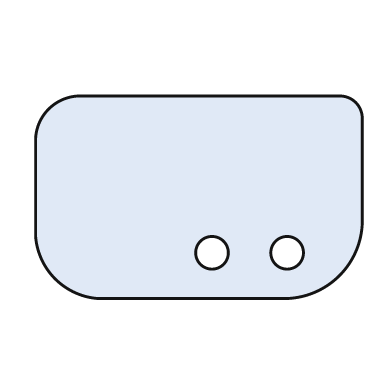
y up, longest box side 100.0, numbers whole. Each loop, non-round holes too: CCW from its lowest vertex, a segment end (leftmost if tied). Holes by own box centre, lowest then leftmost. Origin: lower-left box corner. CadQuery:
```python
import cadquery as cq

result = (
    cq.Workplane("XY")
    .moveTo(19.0, 0.0)
    .lineTo(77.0, 0.0)
    .threePointArc((93.0, 7.0), (100.0, 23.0))
    .lineTo(100.0, 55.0)
    .threePointArc((98.0, 60.0), (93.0, 62.0))
    .lineTo(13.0, 62.0)
    .threePointArc((4.0, 58.0), (0.0, 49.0))
    .lineTo(0.0, 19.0)
    .threePointArc((6.0, 6.0), (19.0, 0.0))
    .close()
    .moveTo(54.0, 14.0)
    .circle(5.0)
    .moveTo(77.0, 14.0)
    .circle(5.0)
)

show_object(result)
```